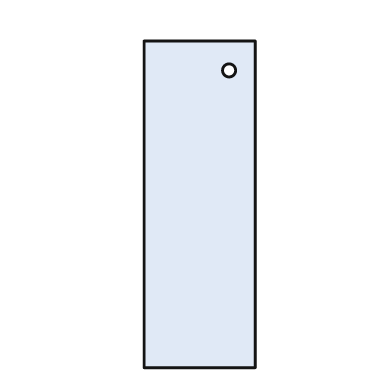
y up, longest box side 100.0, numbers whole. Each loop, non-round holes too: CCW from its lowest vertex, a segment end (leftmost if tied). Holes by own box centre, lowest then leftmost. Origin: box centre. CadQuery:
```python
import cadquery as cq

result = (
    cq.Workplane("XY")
    .moveTo(-17.0, -50.0)
    .lineTo(17.0, -50.0)
    .lineTo(17.0, 50.0)
    .lineTo(-17.0, 50.0)
    .close()
    .moveTo(9.0, 41.0)
    .circle(2.0)
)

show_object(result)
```